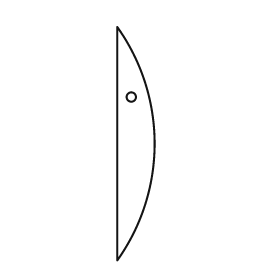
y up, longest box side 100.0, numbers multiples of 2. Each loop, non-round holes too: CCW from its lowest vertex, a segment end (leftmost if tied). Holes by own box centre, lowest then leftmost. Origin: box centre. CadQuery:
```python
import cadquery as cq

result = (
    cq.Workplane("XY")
    .moveTo(-8.0, -50.0)
    .threePointArc((8.0, 0.0), (-8.0, 50.0))
    .close()
    .moveTo(-2.0, 20.0)
    .circle(2.0)
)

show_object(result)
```